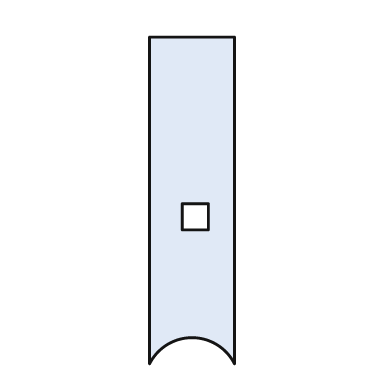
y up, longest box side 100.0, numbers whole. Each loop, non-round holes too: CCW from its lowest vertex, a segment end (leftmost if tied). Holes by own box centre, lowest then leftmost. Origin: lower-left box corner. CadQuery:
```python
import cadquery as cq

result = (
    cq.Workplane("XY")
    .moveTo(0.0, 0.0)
    .threePointArc((13.0, 8.0), (26.0, 0.0))
    .lineTo(26.0, 100.0)
    .lineTo(0.0, 100.0)
    .close()
    .moveTo(10.0, 41.0)
    .lineTo(18.0, 41.0)
    .lineTo(18.0, 49.0)
    .lineTo(10.0, 49.0)
    .close()
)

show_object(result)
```